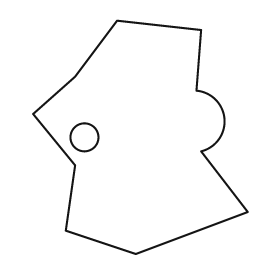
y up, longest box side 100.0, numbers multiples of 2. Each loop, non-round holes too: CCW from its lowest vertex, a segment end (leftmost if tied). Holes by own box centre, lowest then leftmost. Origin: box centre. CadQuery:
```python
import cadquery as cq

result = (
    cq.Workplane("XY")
    .moveTo(-2.0, -50.0)
    .lineTo(46.0, -32.0)
    .lineTo(26.0, -6.0)
    .threePointArc((36.0, 8.0), (24.0, 20.0))
    .lineTo(26.0, 46.0)
    .lineTo(-10.0, 50.0)
    .lineTo(-28.0, 26.0)
    .lineTo(-46.0, 10.0)
    .lineTo(-28.0, -12.0)
    .lineTo(-32.0, -40.0)
    .close()
    .moveTo(-24.0, 0.0)
    .circle(6.0)
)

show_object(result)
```